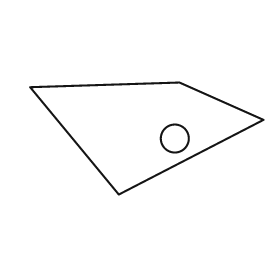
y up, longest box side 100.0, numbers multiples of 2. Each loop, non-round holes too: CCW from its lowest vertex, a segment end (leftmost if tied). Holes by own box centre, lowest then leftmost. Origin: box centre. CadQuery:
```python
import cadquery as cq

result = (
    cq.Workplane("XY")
    .moveTo(-12.0, -24.0)
    .lineTo(50.0, 8.0)
    .lineTo(14.0, 24.0)
    .lineTo(-50.0, 22.0)
    .close()
    .moveTo(12.0, 0.0)
    .circle(6.0)
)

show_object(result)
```